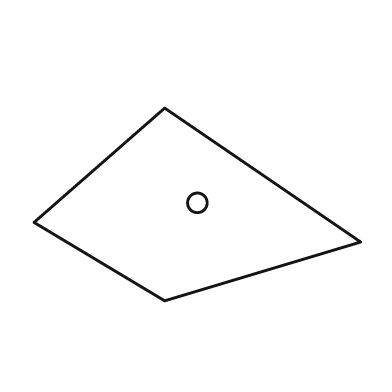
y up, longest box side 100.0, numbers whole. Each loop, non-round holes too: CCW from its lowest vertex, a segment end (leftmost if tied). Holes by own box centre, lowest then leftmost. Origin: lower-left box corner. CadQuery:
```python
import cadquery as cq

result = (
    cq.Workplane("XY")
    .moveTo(40.0, 0.0)
    .lineTo(100.0, 18.0)
    .lineTo(40.0, 59.0)
    .lineTo(0.0, 24.0)
    .close()
    .moveTo(50.0, 30.0)
    .circle(3.0)
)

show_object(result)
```